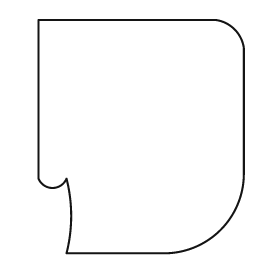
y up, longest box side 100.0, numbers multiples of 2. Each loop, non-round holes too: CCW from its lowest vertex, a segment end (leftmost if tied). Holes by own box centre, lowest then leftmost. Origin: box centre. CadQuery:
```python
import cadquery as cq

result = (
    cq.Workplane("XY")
    .moveTo(-32.0, -50.0)
    .lineTo(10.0, -50.0)
    .threePointArc((34.0, -40.0), (44.0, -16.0))
    .lineTo(44.0, 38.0)
    .threePointArc((40.0, 46.0), (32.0, 50.0))
    .lineTo(-44.0, 50.0)
    .lineTo(-44.0, -18.0)
    .threePointArc((-38.0, -22.0), (-32.0, -18.0))
    .threePointArc((-30.0, -34.0), (-32.0, -50.0))
    .close()
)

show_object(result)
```